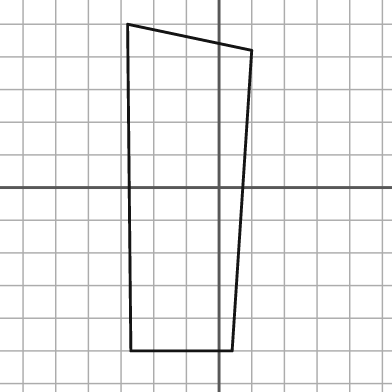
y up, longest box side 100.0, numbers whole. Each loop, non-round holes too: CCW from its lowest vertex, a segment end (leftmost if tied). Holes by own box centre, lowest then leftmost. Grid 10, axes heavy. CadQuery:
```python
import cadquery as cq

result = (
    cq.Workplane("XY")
    .moveTo(-27.0, -50.0)
    .lineTo(4.0, -50.0)
    .lineTo(10.0, 42.0)
    .lineTo(-28.0, 50.0)
    .close()
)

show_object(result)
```